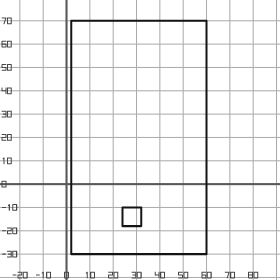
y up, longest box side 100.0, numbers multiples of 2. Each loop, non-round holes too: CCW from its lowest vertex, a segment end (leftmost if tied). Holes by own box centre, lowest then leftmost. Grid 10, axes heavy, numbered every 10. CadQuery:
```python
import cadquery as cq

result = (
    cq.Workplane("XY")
    .moveTo(2.0, -30.0)
    .lineTo(60.0, -30.0)
    .lineTo(60.0, 70.0)
    .lineTo(2.0, 70.0)
    .close()
    .moveTo(24.0, -18.0)
    .lineTo(32.0, -18.0)
    .lineTo(32.0, -10.0)
    .lineTo(24.0, -10.0)
    .close()
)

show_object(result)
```